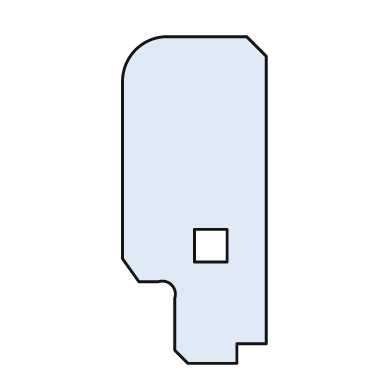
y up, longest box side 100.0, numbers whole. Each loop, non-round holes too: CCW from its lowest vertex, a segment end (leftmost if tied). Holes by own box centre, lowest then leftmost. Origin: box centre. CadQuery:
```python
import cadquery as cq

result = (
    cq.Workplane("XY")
    .moveTo(-2.0, -50.0)
    .lineTo(13.0, -50.0)
    .lineTo(13.0, -44.0)
    .lineTo(22.0, -44.0)
    .lineTo(22.0, 44.0)
    .lineTo(16.0, 50.0)
    .lineTo(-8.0, 50.0)
    .threePointArc((-18.0, 46.0), (-22.0, 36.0))
    .lineTo(-22.0, -18.0)
    .lineTo(-17.0, -25.0)
    .lineTo(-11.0, -25.0)
    .threePointArc((-7.0, -26.0), (-6.0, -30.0))
    .lineTo(-6.0, -46.0)
    .close()
    .moveTo(0.0, -19.0)
    .lineTo(10.0, -19.0)
    .lineTo(10.0, -9.0)
    .lineTo(0.0, -9.0)
    .close()
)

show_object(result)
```